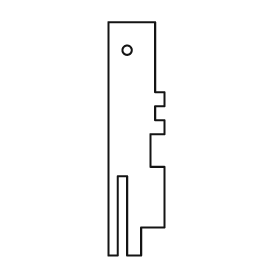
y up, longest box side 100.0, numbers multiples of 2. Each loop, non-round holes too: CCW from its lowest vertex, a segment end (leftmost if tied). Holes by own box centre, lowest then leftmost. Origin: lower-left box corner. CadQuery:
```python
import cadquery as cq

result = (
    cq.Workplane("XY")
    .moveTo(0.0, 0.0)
    .lineTo(4.0, 0.0)
    .lineTo(4.0, 34.0)
    .lineTo(8.0, 34.0)
    .lineTo(8.0, 0.0)
    .lineTo(14.0, 0.0)
    .lineTo(14.0, 12.0)
    .lineTo(24.0, 12.0)
    .lineTo(24.0, 38.0)
    .lineTo(18.0, 38.0)
    .lineTo(18.0, 52.0)
    .lineTo(24.0, 52.0)
    .lineTo(24.0, 58.0)
    .lineTo(20.0, 58.0)
    .lineTo(20.0, 64.0)
    .lineTo(24.0, 64.0)
    .lineTo(24.0, 70.0)
    .lineTo(20.0, 70.0)
    .lineTo(20.0, 100.0)
    .lineTo(0.0, 100.0)
    .close()
    .moveTo(8.0, 88.0)
    .circle(2.0)
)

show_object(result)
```